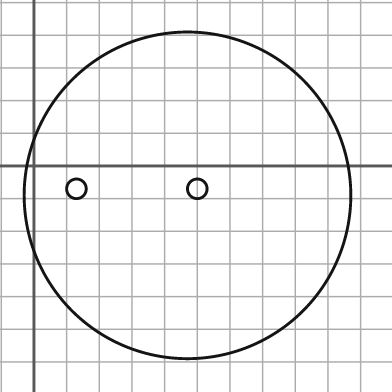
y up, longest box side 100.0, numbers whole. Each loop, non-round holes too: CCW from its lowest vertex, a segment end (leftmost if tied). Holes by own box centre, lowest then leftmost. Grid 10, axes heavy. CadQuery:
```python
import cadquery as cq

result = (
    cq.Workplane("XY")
    .moveTo(47.0, -9.0)
    .circle(50.0)
    .moveTo(13.0, -7.0)
    .circle(3.0)
    .moveTo(50.0, -7.0)
    .circle(3.0)
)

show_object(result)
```